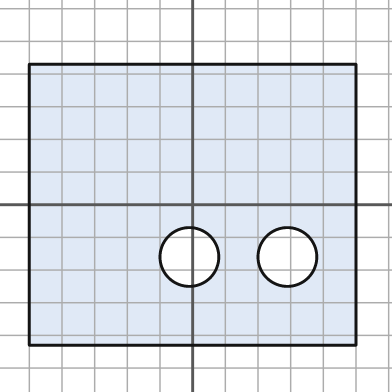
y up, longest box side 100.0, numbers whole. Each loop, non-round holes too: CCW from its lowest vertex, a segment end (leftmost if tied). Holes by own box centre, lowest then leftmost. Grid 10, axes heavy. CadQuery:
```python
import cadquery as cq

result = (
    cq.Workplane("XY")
    .moveTo(-50.0, -43.0)
    .lineTo(50.0, -43.0)
    .lineTo(50.0, 43.0)
    .lineTo(-50.0, 43.0)
    .close()
    .moveTo(-1.0, -16.0)
    .circle(9.0)
    .moveTo(29.0, -16.0)
    .circle(9.0)
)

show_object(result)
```